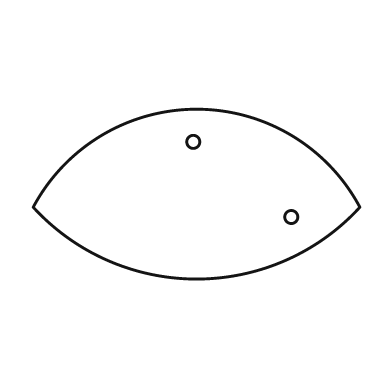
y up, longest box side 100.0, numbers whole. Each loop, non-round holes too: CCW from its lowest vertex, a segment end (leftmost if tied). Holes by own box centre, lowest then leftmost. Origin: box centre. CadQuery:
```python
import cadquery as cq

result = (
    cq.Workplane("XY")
    .moveTo(-50.0, -4.0)
    .threePointArc((0.0, -26.0), (50.0, -4.0))
    .threePointArc((0.0, 26.0), (-50.0, -4.0))
    .close()
    .moveTo(29.0, -7.0)
    .circle(2.0)
    .moveTo(-1.0, 16.0)
    .circle(2.0)
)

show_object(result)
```